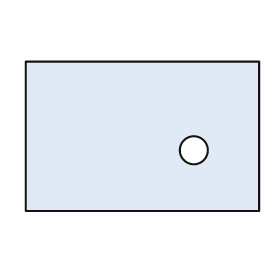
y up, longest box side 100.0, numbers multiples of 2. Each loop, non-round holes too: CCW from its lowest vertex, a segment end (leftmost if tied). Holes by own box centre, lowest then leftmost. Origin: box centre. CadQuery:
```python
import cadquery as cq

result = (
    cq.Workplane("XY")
    .moveTo(-50.0, -32.0)
    .lineTo(50.0, -32.0)
    .lineTo(50.0, 32.0)
    .lineTo(-50.0, 32.0)
    .close()
    .moveTo(22.0, -6.0)
    .circle(6.0)
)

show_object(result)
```